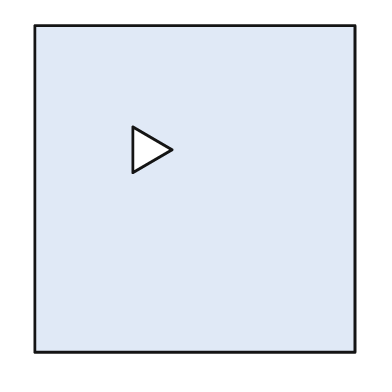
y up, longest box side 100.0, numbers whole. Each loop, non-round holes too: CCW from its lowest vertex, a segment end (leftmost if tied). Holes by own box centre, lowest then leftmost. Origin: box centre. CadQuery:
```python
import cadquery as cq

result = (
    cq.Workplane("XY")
    .moveTo(-49.0, -50.0)
    .lineTo(49.0, -50.0)
    .lineTo(49.0, 50.0)
    .lineTo(-49.0, 50.0)
    .close()
    .moveTo(-19.0, 5.0)
    .lineTo(-7.0, 12.0)
    .lineTo(-19.0, 19.0)
    .close()
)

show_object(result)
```